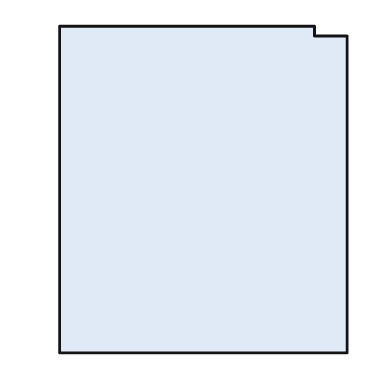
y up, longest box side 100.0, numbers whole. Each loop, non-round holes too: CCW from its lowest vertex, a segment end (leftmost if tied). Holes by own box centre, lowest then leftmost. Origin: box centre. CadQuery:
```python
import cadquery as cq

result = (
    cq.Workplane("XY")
    .moveTo(-44.0, -50.0)
    .lineTo(44.0, -50.0)
    .lineTo(44.0, 47.0)
    .lineTo(34.0, 47.0)
    .lineTo(34.0, 50.0)
    .lineTo(-44.0, 50.0)
    .close()
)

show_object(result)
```